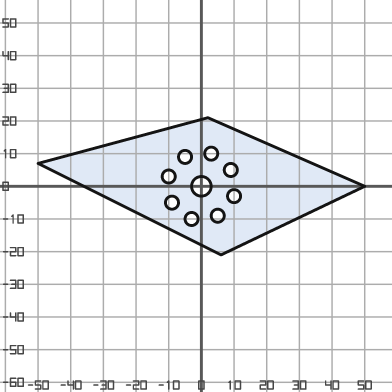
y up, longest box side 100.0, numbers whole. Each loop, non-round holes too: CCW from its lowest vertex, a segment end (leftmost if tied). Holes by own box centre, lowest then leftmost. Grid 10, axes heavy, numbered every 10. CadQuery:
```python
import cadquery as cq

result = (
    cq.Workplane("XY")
    .moveTo(6.0, -21.0)
    .lineTo(50.0, 0.0)
    .lineTo(2.0, 21.0)
    .lineTo(-50.0, 7.0)
    .close()
    .moveTo(-3.0, -10.0)
    .circle(2.0)
    .moveTo(5.0, -9.0)
    .circle(2.0)
    .moveTo(-9.0, -5.0)
    .circle(2.0)
    .moveTo(10.0, -3.0)
    .circle(2.0)
    .moveTo(0.0, 0.0)
    .circle(3.0)
    .moveTo(-10.0, 3.0)
    .circle(2.0)
    .moveTo(9.0, 5.0)
    .circle(2.0)
    .moveTo(-5.0, 9.0)
    .circle(2.0)
    .moveTo(3.0, 10.0)
    .circle(2.0)
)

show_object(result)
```